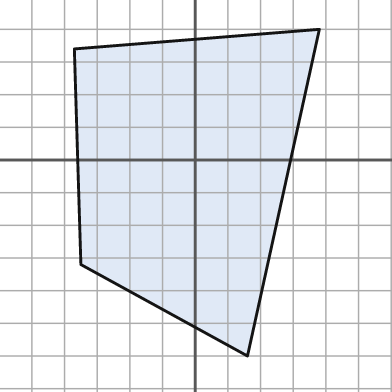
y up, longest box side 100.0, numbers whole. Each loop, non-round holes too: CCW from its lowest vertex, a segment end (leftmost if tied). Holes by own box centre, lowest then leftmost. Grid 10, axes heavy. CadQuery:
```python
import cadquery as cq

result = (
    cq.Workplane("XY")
    .moveTo(16.0, -60.0)
    .lineTo(38.0, 40.0)
    .lineTo(-37.0, 34.0)
    .lineTo(-35.0, -32.0)
    .close()
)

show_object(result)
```